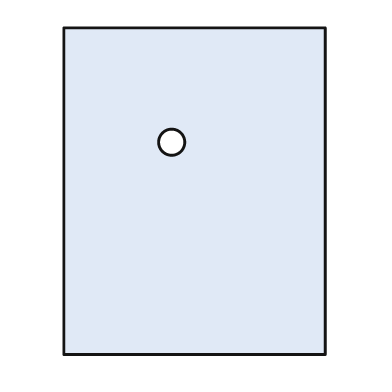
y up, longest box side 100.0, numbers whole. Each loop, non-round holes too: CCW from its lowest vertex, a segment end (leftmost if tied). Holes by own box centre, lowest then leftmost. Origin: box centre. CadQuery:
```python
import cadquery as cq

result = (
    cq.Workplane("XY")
    .moveTo(-40.0, -50.0)
    .lineTo(40.0, -50.0)
    .lineTo(40.0, 50.0)
    .lineTo(-40.0, 50.0)
    .close()
    .moveTo(-7.0, 15.0)
    .circle(4.0)
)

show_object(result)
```